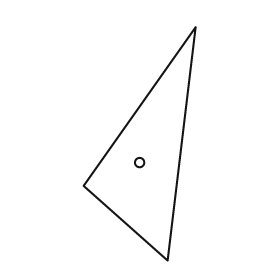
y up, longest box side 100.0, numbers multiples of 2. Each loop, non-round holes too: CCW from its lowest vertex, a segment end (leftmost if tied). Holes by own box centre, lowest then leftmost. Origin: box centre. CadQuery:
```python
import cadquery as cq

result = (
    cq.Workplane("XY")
    .moveTo(12.0, -50.0)
    .lineTo(24.0, 50.0)
    .lineTo(-24.0, -18.0)
    .close()
    .moveTo(0.0, -8.0)
    .circle(2.0)
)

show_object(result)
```